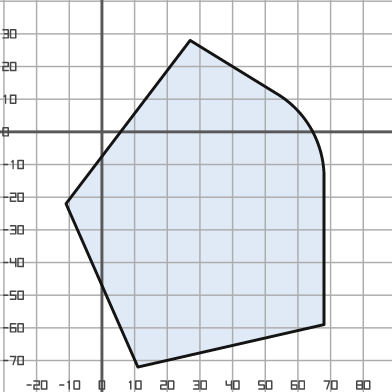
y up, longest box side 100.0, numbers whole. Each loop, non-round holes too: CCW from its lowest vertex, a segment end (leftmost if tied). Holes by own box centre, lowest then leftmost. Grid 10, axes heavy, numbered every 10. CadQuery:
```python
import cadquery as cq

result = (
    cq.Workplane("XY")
    .moveTo(11.0, -72.0)
    .lineTo(68.0, -59.0)
    .lineTo(68.0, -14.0)
    .threePointArc((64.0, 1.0), (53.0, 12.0))
    .lineTo(27.0, 28.0)
    .lineTo(-11.0, -22.0)
    .close()
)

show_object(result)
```